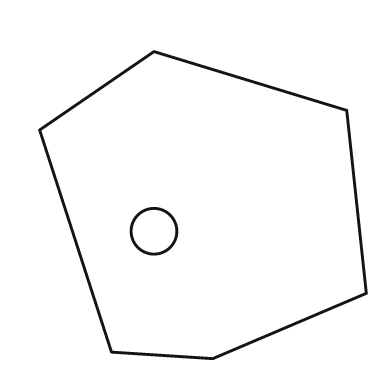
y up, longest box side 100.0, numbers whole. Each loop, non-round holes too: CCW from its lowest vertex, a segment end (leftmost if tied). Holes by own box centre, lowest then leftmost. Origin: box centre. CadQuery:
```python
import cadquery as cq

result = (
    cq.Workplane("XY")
    .moveTo(3.0, -47.0)
    .lineTo(50.0, -27.0)
    .lineTo(44.0, 29.0)
    .lineTo(-15.0, 47.0)
    .lineTo(-50.0, 23.0)
    .lineTo(-28.0, -45.0)
    .close()
    .moveTo(-15.0, -8.0)
    .circle(7.0)
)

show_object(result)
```